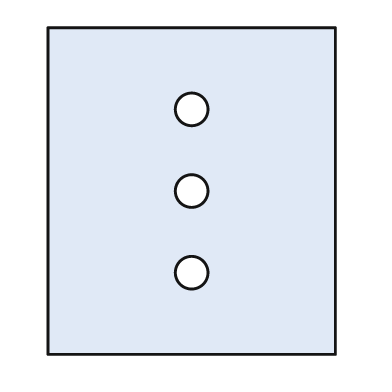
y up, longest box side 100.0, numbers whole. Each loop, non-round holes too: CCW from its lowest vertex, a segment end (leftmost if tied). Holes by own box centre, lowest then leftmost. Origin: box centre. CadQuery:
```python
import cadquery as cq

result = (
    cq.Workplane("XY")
    .moveTo(-44.0, -50.0)
    .lineTo(44.0, -50.0)
    .lineTo(44.0, 50.0)
    .lineTo(-44.0, 50.0)
    .close()
    .moveTo(0.0, -25.0)
    .circle(5.0)
    .moveTo(0.0, 0.0)
    .circle(5.0)
    .moveTo(0.0, 25.0)
    .circle(5.0)
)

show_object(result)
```